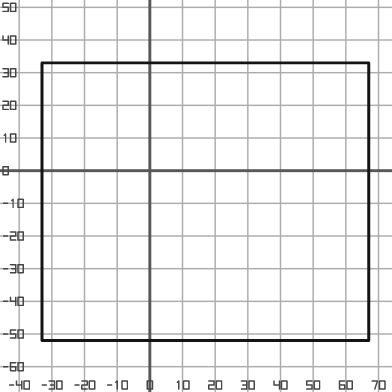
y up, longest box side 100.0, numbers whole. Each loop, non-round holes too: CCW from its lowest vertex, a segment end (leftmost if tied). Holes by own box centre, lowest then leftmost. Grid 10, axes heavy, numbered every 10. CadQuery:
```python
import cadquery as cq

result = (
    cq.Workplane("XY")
    .moveTo(-33.0, -52.0)
    .lineTo(67.0, -52.0)
    .lineTo(67.0, 33.0)
    .lineTo(-33.0, 33.0)
    .close()
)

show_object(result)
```